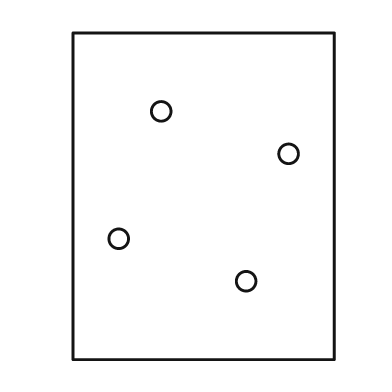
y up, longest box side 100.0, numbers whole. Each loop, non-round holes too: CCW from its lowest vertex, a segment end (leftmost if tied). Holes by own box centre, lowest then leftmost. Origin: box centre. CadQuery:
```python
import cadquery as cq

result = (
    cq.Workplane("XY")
    .moveTo(-40.0, -50.0)
    .lineTo(40.0, -50.0)
    .lineTo(40.0, 50.0)
    .lineTo(-40.0, 50.0)
    .close()
    .moveTo(13.0, -26.0)
    .circle(3.0)
    .moveTo(-26.0, -13.0)
    .circle(3.0)
    .moveTo(26.0, 13.0)
    .circle(3.0)
    .moveTo(-13.0, 26.0)
    .circle(3.0)
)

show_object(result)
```